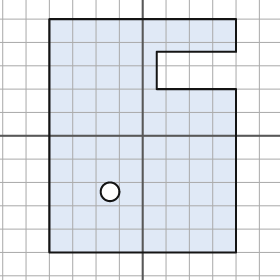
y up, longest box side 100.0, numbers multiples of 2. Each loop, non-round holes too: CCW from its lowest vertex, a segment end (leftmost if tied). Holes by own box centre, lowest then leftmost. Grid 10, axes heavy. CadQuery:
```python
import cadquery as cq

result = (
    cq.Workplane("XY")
    .moveTo(-40.0, -50.0)
    .lineTo(40.0, -50.0)
    .lineTo(40.0, 20.0)
    .lineTo(6.0, 20.0)
    .lineTo(6.0, 36.0)
    .lineTo(40.0, 36.0)
    .lineTo(40.0, 50.0)
    .lineTo(-40.0, 50.0)
    .close()
    .moveTo(-14.0, -24.0)
    .circle(4.0)
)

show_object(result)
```